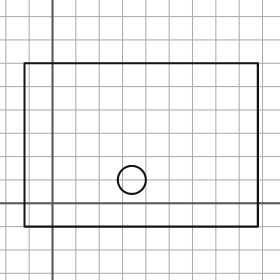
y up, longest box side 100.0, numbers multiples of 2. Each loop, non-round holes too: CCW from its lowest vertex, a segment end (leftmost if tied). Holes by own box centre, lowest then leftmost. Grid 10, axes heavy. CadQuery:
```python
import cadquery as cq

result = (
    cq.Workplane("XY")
    .moveTo(-12.0, -10.0)
    .lineTo(88.0, -10.0)
    .lineTo(88.0, 60.0)
    .lineTo(-12.0, 60.0)
    .close()
    .moveTo(34.0, 10.0)
    .circle(6.0)
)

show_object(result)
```